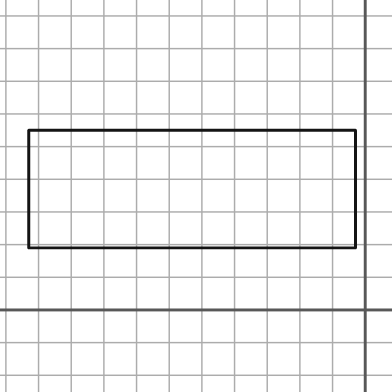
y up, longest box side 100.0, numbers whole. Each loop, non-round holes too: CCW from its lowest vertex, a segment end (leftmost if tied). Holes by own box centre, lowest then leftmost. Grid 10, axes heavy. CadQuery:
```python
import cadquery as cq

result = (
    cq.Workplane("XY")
    .moveTo(-103.0, 19.0)
    .lineTo(-3.0, 19.0)
    .lineTo(-3.0, 55.0)
    .lineTo(-103.0, 55.0)
    .close()
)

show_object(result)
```